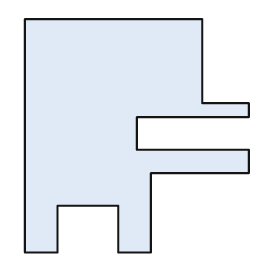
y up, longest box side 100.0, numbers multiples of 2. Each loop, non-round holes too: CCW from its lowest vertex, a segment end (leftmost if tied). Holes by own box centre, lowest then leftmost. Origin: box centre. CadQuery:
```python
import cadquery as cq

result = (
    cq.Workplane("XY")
    .moveTo(-48.0, -50.0)
    .lineTo(-34.0, -50.0)
    .lineTo(-34.0, -30.0)
    .lineTo(-8.0, -30.0)
    .lineTo(-8.0, -50.0)
    .lineTo(6.0, -50.0)
    .lineTo(6.0, -16.0)
    .lineTo(48.0, -16.0)
    .lineTo(48.0, -6.0)
    .lineTo(0.0, -6.0)
    .lineTo(0.0, 8.0)
    .lineTo(48.0, 8.0)
    .lineTo(48.0, 14.0)
    .lineTo(28.0, 14.0)
    .lineTo(28.0, 50.0)
    .lineTo(-48.0, 50.0)
    .close()
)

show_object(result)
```